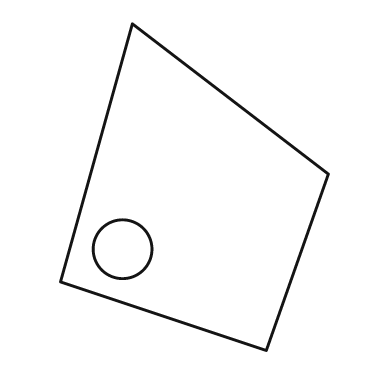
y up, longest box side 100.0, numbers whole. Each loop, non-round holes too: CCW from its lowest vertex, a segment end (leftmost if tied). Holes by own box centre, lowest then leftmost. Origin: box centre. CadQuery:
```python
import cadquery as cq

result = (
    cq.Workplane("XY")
    .moveTo(22.0, -50.0)
    .lineTo(41.0, 4.0)
    .lineTo(-19.0, 50.0)
    .lineTo(-41.0, -29.0)
    .close()
    .moveTo(-22.0, -19.0)
    .circle(9.0)
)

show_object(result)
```